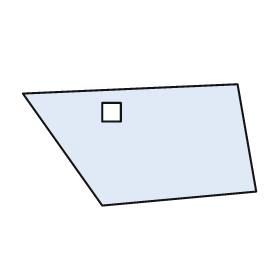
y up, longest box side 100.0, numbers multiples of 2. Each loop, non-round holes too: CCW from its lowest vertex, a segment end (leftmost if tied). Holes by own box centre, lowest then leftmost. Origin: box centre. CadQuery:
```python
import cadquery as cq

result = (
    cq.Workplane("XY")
    .moveTo(-16.0, -26.0)
    .lineTo(50.0, -20.0)
    .lineTo(42.0, 26.0)
    .lineTo(-50.0, 22.0)
    .close()
    .moveTo(-16.0, 10.0)
    .lineTo(-8.0, 10.0)
    .lineTo(-8.0, 18.0)
    .lineTo(-16.0, 18.0)
    .close()
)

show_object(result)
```